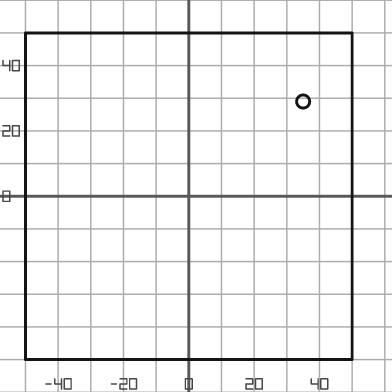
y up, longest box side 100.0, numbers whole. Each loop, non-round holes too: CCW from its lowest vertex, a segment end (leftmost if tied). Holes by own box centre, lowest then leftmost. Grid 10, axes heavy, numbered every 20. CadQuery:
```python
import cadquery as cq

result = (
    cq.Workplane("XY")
    .moveTo(-50.0, -50.0)
    .lineTo(50.0, -50.0)
    .lineTo(50.0, 50.0)
    .lineTo(-50.0, 50.0)
    .close()
    .moveTo(35.0, 29.0)
    .circle(2.0)
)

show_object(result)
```